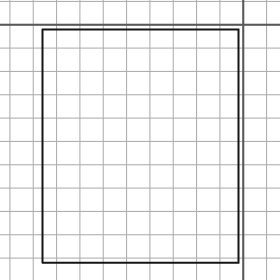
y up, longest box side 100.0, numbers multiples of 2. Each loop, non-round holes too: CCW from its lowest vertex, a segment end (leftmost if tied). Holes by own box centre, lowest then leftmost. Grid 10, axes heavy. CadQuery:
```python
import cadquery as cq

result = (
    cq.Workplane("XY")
    .moveTo(-86.0, -102.0)
    .lineTo(-2.0, -102.0)
    .lineTo(-2.0, -2.0)
    .lineTo(-86.0, -2.0)
    .close()
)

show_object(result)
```